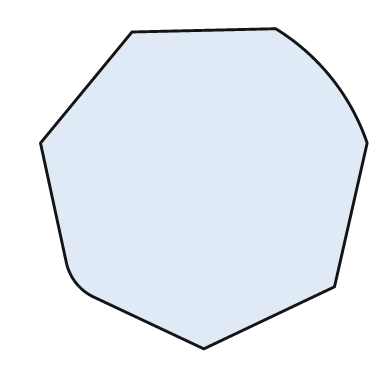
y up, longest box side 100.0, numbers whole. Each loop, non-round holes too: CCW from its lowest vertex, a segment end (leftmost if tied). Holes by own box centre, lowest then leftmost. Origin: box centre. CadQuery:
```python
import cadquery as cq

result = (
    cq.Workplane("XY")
    .moveTo(0.0, -49.0)
    .lineTo(40.0, -30.0)
    .lineTo(50.0, 14.0)
    .threePointArc((39.0, 34.0), (22.0, 49.0))
    .lineTo(-22.0, 48.0)
    .lineTo(-50.0, 14.0)
    .lineTo(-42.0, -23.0)
    .threePointArc((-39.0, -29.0), (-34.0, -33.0))
    .close()
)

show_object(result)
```